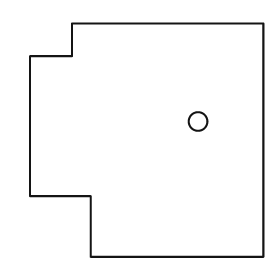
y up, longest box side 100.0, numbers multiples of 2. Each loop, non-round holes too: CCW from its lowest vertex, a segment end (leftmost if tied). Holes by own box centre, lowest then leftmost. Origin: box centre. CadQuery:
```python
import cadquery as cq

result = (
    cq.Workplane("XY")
    .moveTo(-24.0, -50.0)
    .lineTo(50.0, -50.0)
    .lineTo(50.0, 50.0)
    .lineTo(-32.0, 50.0)
    .lineTo(-32.0, 36.0)
    .lineTo(-50.0, 36.0)
    .lineTo(-50.0, -24.0)
    .lineTo(-24.0, -24.0)
    .close()
    .moveTo(22.0, 8.0)
    .circle(4.0)
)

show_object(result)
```